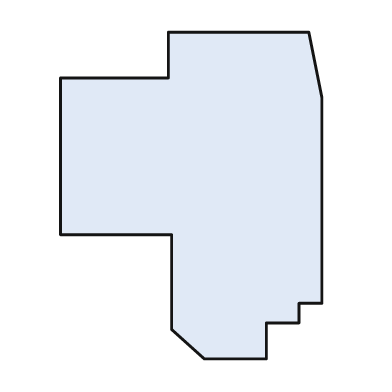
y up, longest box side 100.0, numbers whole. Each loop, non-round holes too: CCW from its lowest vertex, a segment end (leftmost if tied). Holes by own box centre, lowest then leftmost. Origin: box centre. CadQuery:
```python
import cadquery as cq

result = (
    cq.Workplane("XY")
    .moveTo(4.0, -50.0)
    .lineTo(23.0, -50.0)
    .lineTo(23.0, -39.0)
    .lineTo(33.0, -39.0)
    .lineTo(33.0, -33.0)
    .lineTo(40.0, -33.0)
    .lineTo(40.0, 30.0)
    .lineTo(36.0, 50.0)
    .lineTo(-7.0, 50.0)
    .lineTo(-7.0, 36.0)
    .lineTo(-40.0, 36.0)
    .lineTo(-40.0, -12.0)
    .lineTo(-6.0, -12.0)
    .lineTo(-6.0, -41.0)
    .close()
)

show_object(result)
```